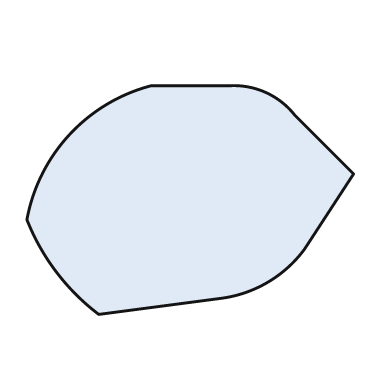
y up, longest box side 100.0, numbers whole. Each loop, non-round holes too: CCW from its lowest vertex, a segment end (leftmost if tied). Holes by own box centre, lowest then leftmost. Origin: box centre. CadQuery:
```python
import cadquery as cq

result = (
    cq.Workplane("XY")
    .moveTo(-28.0, -35.0)
    .lineTo(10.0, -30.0)
    .threePointArc((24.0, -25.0), (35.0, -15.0))
    .lineTo(50.0, 8.0)
    .lineTo(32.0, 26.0)
    .threePointArc((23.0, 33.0), (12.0, 35.0))
    .lineTo(-12.0, 35.0)
    .threePointArc((-37.0, 20.0), (-50.0, -6.0))
    .threePointArc((-41.0, -22.0), (-28.0, -35.0))
    .close()
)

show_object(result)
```